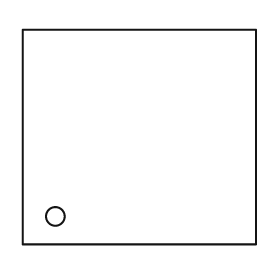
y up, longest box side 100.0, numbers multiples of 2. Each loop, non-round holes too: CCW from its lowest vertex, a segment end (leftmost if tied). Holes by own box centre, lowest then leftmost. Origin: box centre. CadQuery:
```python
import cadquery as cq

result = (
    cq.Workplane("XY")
    .moveTo(-50.0, -46.0)
    .lineTo(50.0, -46.0)
    .lineTo(50.0, 46.0)
    .lineTo(-50.0, 46.0)
    .close()
    .moveTo(-36.0, -34.0)
    .circle(4.0)
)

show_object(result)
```